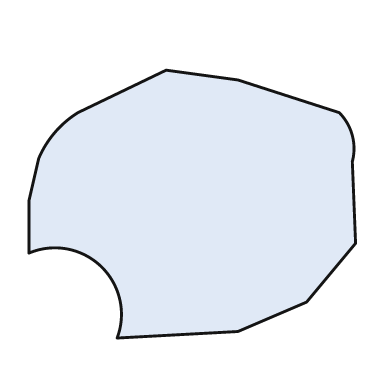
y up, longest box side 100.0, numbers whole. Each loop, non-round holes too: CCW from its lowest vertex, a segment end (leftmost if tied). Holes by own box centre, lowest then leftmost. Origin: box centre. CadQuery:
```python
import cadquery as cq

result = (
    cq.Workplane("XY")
    .moveTo(-23.0, -41.0)
    .lineTo(14.0, -39.0)
    .lineTo(35.0, -30.0)
    .lineTo(50.0, -12.0)
    .lineTo(49.0, 13.0)
    .threePointArc((49.0, 21.0), (45.0, 28.0))
    .lineTo(14.0, 38.0)
    .lineTo(-8.0, 41.0)
    .lineTo(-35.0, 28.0)
    .threePointArc((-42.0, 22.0), (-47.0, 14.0))
    .lineTo(-50.0, 1.0)
    .lineTo(-50.0, -15.0)
    .threePointArc((-28.0, -19.0), (-23.0, -41.0))
    .close()
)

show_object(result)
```